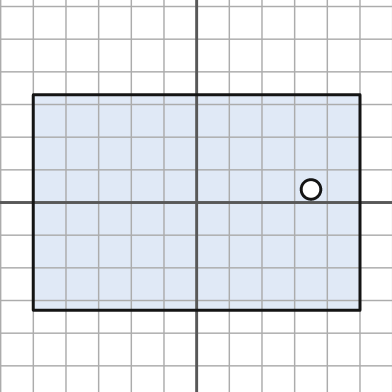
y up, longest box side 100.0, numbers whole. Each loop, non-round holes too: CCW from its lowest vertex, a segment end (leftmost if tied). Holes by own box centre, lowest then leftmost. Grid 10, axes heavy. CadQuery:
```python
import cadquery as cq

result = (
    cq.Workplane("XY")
    .moveTo(-50.0, -33.0)
    .lineTo(50.0, -33.0)
    .lineTo(50.0, 33.0)
    .lineTo(-50.0, 33.0)
    .close()
    .moveTo(35.0, 4.0)
    .circle(3.0)
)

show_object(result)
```